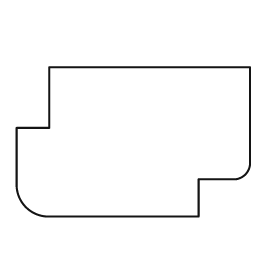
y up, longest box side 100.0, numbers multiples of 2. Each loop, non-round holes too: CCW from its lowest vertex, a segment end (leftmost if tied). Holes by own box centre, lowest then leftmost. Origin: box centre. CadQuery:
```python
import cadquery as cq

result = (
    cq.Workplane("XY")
    .moveTo(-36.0, -32.0)
    .lineTo(28.0, -32.0)
    .lineTo(28.0, -16.0)
    .lineTo(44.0, -16.0)
    .threePointArc((48.0, -14.0), (50.0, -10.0))
    .lineTo(50.0, 32.0)
    .lineTo(-36.0, 32.0)
    .lineTo(-36.0, 6.0)
    .lineTo(-50.0, 6.0)
    .lineTo(-50.0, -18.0)
    .threePointArc((-46.0, -28.0), (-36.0, -32.0))
    .close()
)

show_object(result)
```